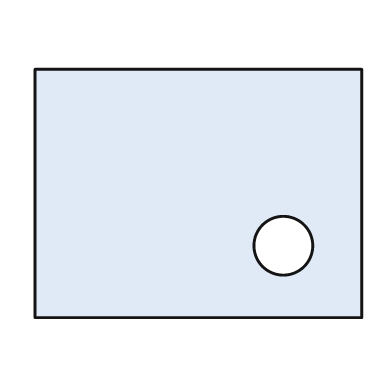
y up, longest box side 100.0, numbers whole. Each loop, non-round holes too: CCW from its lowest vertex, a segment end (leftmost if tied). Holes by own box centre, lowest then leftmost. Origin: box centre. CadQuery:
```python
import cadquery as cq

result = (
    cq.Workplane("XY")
    .moveTo(-50.0, -38.0)
    .lineTo(50.0, -38.0)
    .lineTo(50.0, 38.0)
    .lineTo(-50.0, 38.0)
    .close()
    .moveTo(26.0, -16.0)
    .circle(9.0)
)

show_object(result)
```